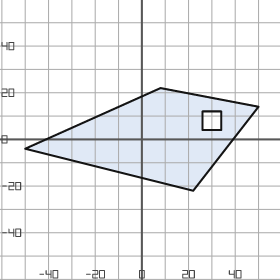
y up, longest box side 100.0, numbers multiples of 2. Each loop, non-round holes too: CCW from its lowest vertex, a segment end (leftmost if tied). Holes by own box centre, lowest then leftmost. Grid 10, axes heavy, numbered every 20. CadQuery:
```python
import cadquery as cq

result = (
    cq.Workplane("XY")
    .moveTo(22.0, -22.0)
    .lineTo(50.0, 14.0)
    .lineTo(8.0, 22.0)
    .lineTo(-50.0, -4.0)
    .close()
    .moveTo(26.0, 4.0)
    .lineTo(34.0, 4.0)
    .lineTo(34.0, 12.0)
    .lineTo(26.0, 12.0)
    .close()
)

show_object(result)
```